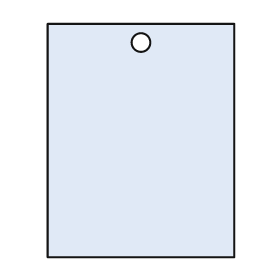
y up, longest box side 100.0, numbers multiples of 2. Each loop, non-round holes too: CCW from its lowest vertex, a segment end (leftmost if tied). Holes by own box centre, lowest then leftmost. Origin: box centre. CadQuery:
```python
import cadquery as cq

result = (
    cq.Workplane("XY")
    .moveTo(-40.0, -50.0)
    .lineTo(40.0, -50.0)
    .lineTo(40.0, 50.0)
    .lineTo(-40.0, 50.0)
    .close()
    .moveTo(0.0, 42.0)
    .circle(4.0)
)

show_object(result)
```